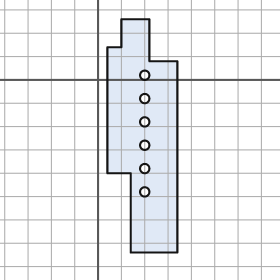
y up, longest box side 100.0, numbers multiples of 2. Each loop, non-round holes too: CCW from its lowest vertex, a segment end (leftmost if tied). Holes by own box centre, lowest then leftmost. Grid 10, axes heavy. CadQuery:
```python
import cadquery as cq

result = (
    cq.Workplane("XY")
    .moveTo(14.0, -74.0)
    .lineTo(34.0, -74.0)
    .lineTo(34.0, 8.0)
    .lineTo(22.0, 8.0)
    .lineTo(22.0, 26.0)
    .lineTo(10.0, 26.0)
    .lineTo(10.0, 14.0)
    .lineTo(4.0, 14.0)
    .lineTo(4.0, -40.0)
    .lineTo(14.0, -40.0)
    .close()
    .moveTo(20.0, -48.0)
    .circle(2.0)
    .moveTo(20.0, -38.0)
    .circle(2.0)
    .moveTo(20.0, -28.0)
    .circle(2.0)
    .moveTo(20.0, -18.0)
    .circle(2.0)
    .moveTo(20.0, -8.0)
    .circle(2.0)
    .moveTo(20.0, 2.0)
    .circle(2.0)
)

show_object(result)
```